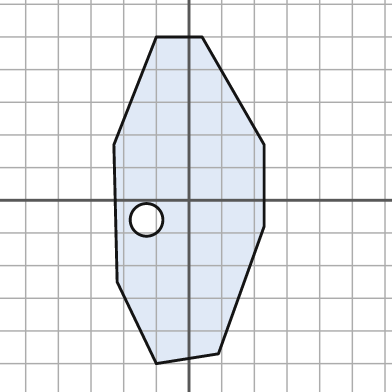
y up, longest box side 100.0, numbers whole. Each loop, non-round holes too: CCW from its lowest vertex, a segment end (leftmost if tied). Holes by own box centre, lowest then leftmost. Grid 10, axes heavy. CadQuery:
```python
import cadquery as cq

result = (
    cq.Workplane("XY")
    .moveTo(-10.0, -50.0)
    .lineTo(9.0, -47.0)
    .lineTo(23.0, -8.0)
    .lineTo(23.0, 17.0)
    .lineTo(4.0, 50.0)
    .lineTo(-10.0, 50.0)
    .lineTo(-23.0, 17.0)
    .lineTo(-22.0, -25.0)
    .close()
    .moveTo(-13.0, -6.0)
    .circle(5.0)
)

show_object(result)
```